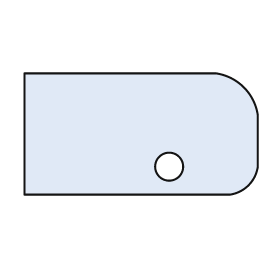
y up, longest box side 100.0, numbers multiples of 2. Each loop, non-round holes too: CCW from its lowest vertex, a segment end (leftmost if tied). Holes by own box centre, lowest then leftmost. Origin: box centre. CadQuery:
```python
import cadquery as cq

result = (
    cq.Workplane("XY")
    .moveTo(-50.0, -26.0)
    .lineTo(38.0, -26.0)
    .threePointArc((46.0, -22.0), (50.0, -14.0))
    .lineTo(50.0, 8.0)
    .threePointArc((44.0, 20.0), (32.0, 26.0))
    .lineTo(-50.0, 26.0)
    .close()
    .moveTo(12.0, -14.0)
    .circle(6.0)
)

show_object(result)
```